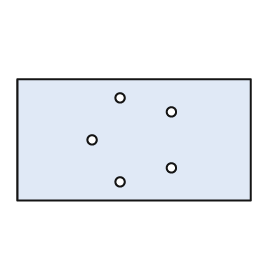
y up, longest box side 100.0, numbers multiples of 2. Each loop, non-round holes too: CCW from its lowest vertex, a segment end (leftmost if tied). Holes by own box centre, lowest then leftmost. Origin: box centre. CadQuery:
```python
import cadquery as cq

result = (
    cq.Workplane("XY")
    .moveTo(-50.0, -26.0)
    .lineTo(50.0, -26.0)
    .lineTo(50.0, 26.0)
    .lineTo(-50.0, 26.0)
    .close()
    .moveTo(-6.0, -18.0)
    .circle(2.0)
    .moveTo(16.0, -12.0)
    .circle(2.0)
    .moveTo(-18.0, 0.0)
    .circle(2.0)
    .moveTo(16.0, 12.0)
    .circle(2.0)
    .moveTo(-6.0, 18.0)
    .circle(2.0)
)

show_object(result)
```